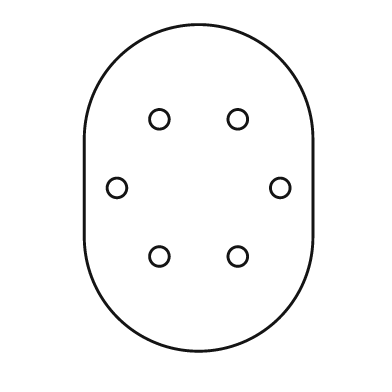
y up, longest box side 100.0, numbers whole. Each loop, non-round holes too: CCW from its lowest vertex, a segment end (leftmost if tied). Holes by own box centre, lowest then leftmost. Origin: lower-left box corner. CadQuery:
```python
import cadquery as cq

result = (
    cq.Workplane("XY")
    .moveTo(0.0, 35.0)
    .threePointArc((35.0, 0.0), (70.0, 35.0))
    .lineTo(70.0, 65.0)
    .threePointArc((35.0, 100.0), (0.0, 65.0))
    .close()
    .moveTo(23.0, 29.0)
    .circle(3.0)
    .moveTo(47.0, 29.0)
    .circle(3.0)
    .moveTo(10.0, 50.0)
    .circle(3.0)
    .moveTo(60.0, 50.0)
    .circle(3.0)
    .moveTo(23.0, 71.0)
    .circle(3.0)
    .moveTo(47.0, 71.0)
    .circle(3.0)
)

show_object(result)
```